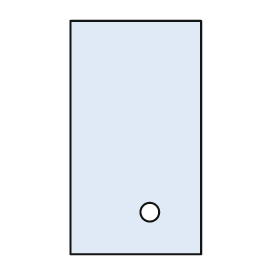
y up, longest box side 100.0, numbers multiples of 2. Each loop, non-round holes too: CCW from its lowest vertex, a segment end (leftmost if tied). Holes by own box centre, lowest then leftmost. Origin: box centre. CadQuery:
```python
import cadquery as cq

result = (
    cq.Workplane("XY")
    .moveTo(-28.0, -50.0)
    .lineTo(28.0, -50.0)
    .lineTo(28.0, 50.0)
    .lineTo(-28.0, 50.0)
    .close()
    .moveTo(6.0, -32.0)
    .circle(4.0)
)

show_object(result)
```